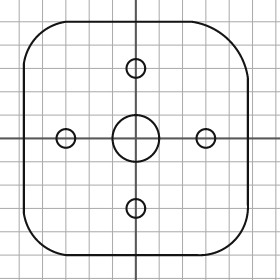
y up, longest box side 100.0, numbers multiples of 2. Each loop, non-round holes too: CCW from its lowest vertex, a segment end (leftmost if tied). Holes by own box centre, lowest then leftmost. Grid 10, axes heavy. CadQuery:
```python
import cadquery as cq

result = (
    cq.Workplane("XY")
    .moveTo(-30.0, -50.0)
    .lineTo(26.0, -50.0)
    .threePointArc((42.0, -44.0), (48.0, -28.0))
    .lineTo(48.0, 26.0)
    .threePointArc((40.0, 42.0), (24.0, 50.0))
    .lineTo(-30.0, 50.0)
    .threePointArc((-42.0, 44.0), (-48.0, 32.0))
    .lineTo(-48.0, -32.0)
    .threePointArc((-42.0, -44.0), (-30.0, -50.0))
    .close()
    .moveTo(0.0, -30.0)
    .circle(4.0)
    .moveTo(-30.0, 0.0)
    .circle(4.0)
    .moveTo(0.0, 0.0)
    .circle(10.0)
    .moveTo(30.0, 0.0)
    .circle(4.0)
    .moveTo(0.0, 30.0)
    .circle(4.0)
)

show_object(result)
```